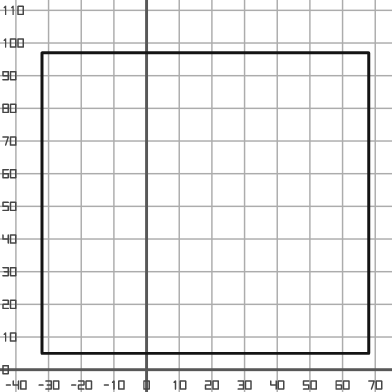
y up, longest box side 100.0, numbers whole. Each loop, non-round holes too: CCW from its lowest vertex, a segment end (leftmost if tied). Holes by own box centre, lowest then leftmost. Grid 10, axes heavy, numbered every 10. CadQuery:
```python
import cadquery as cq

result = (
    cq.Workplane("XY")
    .moveTo(-32.0, 5.0)
    .lineTo(68.0, 5.0)
    .lineTo(68.0, 97.0)
    .lineTo(-32.0, 97.0)
    .close()
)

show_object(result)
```